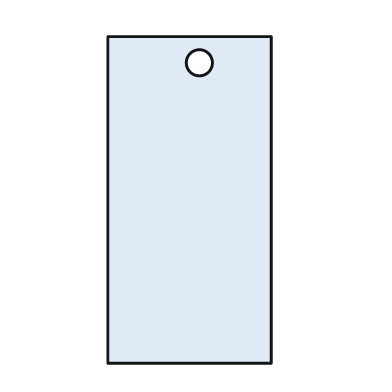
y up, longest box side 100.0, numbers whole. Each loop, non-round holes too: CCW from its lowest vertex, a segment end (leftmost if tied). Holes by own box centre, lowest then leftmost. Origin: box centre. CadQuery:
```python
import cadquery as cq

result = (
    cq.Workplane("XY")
    .moveTo(-25.0, -50.0)
    .lineTo(25.0, -50.0)
    .lineTo(25.0, 50.0)
    .lineTo(-25.0, 50.0)
    .close()
    .moveTo(3.0, 42.0)
    .circle(4.0)
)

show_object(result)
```